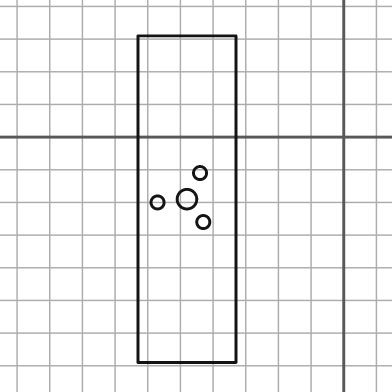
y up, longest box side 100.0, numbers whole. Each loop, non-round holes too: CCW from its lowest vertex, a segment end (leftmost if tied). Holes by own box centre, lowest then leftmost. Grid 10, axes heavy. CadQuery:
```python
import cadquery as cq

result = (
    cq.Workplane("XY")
    .moveTo(-63.0, -69.0)
    .lineTo(-33.0, -69.0)
    .lineTo(-33.0, 31.0)
    .lineTo(-63.0, 31.0)
    .close()
    .moveTo(-43.0, -26.0)
    .circle(2.0)
    .moveTo(-57.0, -20.0)
    .circle(2.0)
    .moveTo(-48.0, -19.0)
    .circle(3.0)
    .moveTo(-44.0, -11.0)
    .circle(2.0)
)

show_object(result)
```